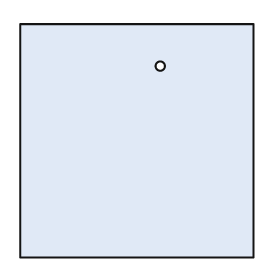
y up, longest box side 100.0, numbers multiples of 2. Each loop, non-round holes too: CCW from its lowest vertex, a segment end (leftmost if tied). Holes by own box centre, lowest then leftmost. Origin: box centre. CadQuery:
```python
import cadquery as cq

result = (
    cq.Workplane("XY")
    .moveTo(-50.0, -50.0)
    .lineTo(50.0, -50.0)
    .lineTo(50.0, 50.0)
    .lineTo(-50.0, 50.0)
    .close()
    .moveTo(10.0, 32.0)
    .circle(2.0)
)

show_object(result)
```